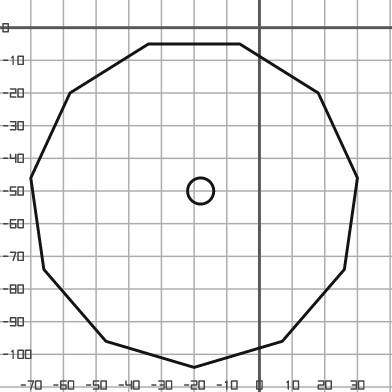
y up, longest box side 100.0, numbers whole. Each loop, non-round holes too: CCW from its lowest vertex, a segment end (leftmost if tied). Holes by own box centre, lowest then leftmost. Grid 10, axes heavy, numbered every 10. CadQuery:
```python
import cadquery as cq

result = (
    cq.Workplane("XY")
    .moveTo(-20.0, -104.0)
    .lineTo(7.0, -96.0)
    .lineTo(26.0, -74.0)
    .lineTo(30.0, -46.0)
    .lineTo(18.0, -20.0)
    .lineTo(-6.0, -5.0)
    .lineTo(-34.0, -5.0)
    .lineTo(-58.0, -20.0)
    .lineTo(-70.0, -46.0)
    .lineTo(-66.0, -74.0)
    .lineTo(-47.0, -96.0)
    .close()
    .moveTo(-18.0, -50.0)
    .circle(4.0)
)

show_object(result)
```